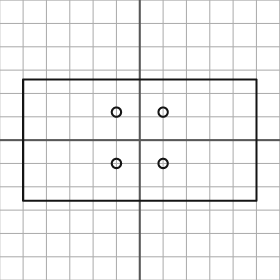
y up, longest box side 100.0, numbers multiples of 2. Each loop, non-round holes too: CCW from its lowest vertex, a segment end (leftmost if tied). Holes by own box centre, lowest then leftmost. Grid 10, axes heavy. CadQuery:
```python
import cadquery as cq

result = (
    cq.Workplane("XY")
    .moveTo(-50.0, -26.0)
    .lineTo(50.0, -26.0)
    .lineTo(50.0, 26.0)
    .lineTo(-50.0, 26.0)
    .close()
    .moveTo(-10.0, -10.0)
    .circle(2.0)
    .moveTo(10.0, -10.0)
    .circle(2.0)
    .moveTo(-10.0, 12.0)
    .circle(2.0)
    .moveTo(10.0, 12.0)
    .circle(2.0)
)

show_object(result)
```